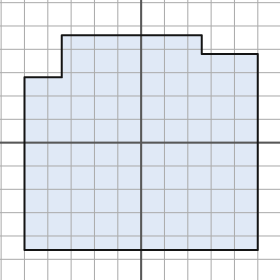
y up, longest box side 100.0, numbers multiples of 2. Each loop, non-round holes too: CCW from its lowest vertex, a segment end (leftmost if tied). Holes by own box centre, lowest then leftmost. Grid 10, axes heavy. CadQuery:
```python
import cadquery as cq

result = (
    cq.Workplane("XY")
    .moveTo(-50.0, -46.0)
    .lineTo(50.0, -46.0)
    .lineTo(50.0, 38.0)
    .lineTo(26.0, 38.0)
    .lineTo(26.0, 46.0)
    .lineTo(-34.0, 46.0)
    .lineTo(-34.0, 28.0)
    .lineTo(-50.0, 28.0)
    .close()
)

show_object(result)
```